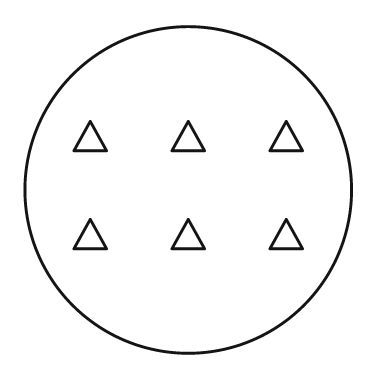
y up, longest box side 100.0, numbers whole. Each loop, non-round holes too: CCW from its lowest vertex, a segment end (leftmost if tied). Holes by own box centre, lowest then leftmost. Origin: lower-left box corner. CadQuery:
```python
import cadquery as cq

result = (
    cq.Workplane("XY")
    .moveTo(50.0, 50.0)
    .circle(50.0)
    .moveTo(15.0, 32.0)
    .lineTo(25.0, 32.0)
    .lineTo(20.0, 41.0)
    .close()
    .moveTo(45.0, 32.0)
    .lineTo(55.0, 32.0)
    .lineTo(50.0, 41.0)
    .close()
    .moveTo(75.0, 32.0)
    .lineTo(85.0, 32.0)
    .lineTo(80.0, 41.0)
    .close()
    .moveTo(15.0, 62.0)
    .lineTo(25.0, 62.0)
    .lineTo(20.0, 71.0)
    .close()
    .moveTo(45.0, 62.0)
    .lineTo(55.0, 62.0)
    .lineTo(50.0, 71.0)
    .close()
    .moveTo(75.0, 62.0)
    .lineTo(85.0, 62.0)
    .lineTo(80.0, 71.0)
    .close()
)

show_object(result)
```